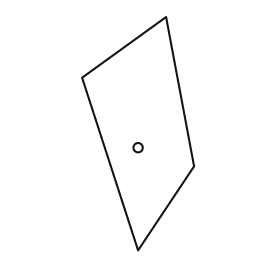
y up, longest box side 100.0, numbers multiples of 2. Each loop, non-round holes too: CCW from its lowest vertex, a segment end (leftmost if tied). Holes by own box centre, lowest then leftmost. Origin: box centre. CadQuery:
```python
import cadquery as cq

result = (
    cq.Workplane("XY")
    .moveTo(0.0, -50.0)
    .lineTo(24.0, -14.0)
    .lineTo(12.0, 50.0)
    .lineTo(-24.0, 24.0)
    .close()
    .moveTo(0.0, -6.0)
    .circle(2.0)
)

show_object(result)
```